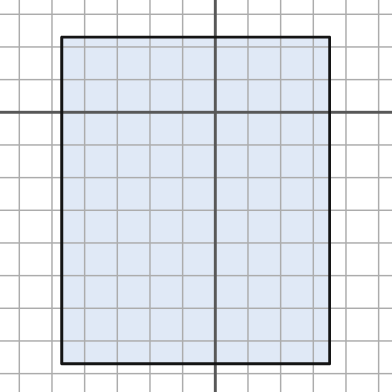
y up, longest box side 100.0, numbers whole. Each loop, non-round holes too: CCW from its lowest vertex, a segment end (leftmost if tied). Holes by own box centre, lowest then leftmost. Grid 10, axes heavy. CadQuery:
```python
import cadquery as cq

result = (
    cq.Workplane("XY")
    .moveTo(-47.0, -77.0)
    .lineTo(35.0, -77.0)
    .lineTo(35.0, 23.0)
    .lineTo(-47.0, 23.0)
    .close()
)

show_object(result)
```